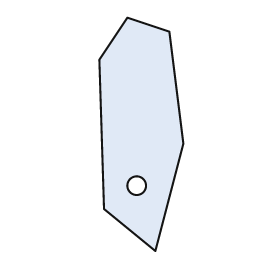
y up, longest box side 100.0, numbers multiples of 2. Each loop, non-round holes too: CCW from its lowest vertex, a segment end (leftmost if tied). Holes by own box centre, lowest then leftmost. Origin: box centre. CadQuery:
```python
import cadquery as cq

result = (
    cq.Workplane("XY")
    .moveTo(6.0, -50.0)
    .lineTo(18.0, -4.0)
    .lineTo(12.0, 44.0)
    .lineTo(-6.0, 50.0)
    .lineTo(-18.0, 32.0)
    .lineTo(-16.0, -32.0)
    .close()
    .moveTo(-2.0, -22.0)
    .circle(4.0)
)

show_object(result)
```